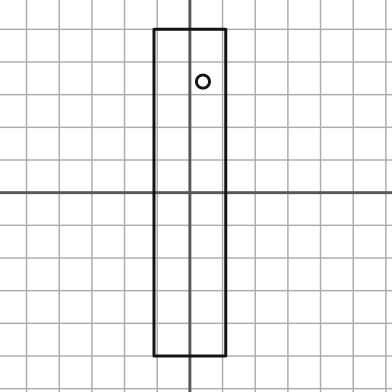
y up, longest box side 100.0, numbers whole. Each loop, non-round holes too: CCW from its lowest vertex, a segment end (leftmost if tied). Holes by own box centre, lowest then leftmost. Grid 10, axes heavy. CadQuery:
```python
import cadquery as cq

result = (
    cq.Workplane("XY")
    .moveTo(-11.0, -50.0)
    .lineTo(11.0, -50.0)
    .lineTo(11.0, 50.0)
    .lineTo(-11.0, 50.0)
    .close()
    .moveTo(4.0, 34.0)
    .circle(2.0)
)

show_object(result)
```